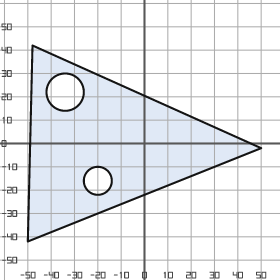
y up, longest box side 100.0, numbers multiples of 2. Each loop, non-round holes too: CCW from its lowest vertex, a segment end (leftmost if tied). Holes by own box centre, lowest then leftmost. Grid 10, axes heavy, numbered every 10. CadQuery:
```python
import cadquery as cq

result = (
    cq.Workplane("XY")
    .moveTo(-50.0, -42.0)
    .lineTo(50.0, -2.0)
    .lineTo(-48.0, 42.0)
    .close()
    .moveTo(-20.0, -16.0)
    .circle(6.0)
    .moveTo(-34.0, 22.0)
    .circle(8.0)
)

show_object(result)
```